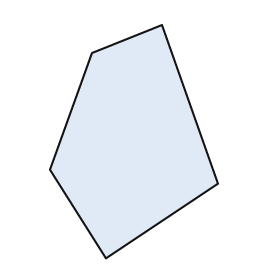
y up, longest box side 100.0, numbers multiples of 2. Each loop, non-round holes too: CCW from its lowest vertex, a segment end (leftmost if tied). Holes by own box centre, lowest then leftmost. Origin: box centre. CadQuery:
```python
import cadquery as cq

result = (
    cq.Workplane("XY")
    .moveTo(-12.0, -50.0)
    .lineTo(36.0, -18.0)
    .lineTo(12.0, 50.0)
    .lineTo(-18.0, 38.0)
    .lineTo(-36.0, -12.0)
    .close()
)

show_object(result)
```